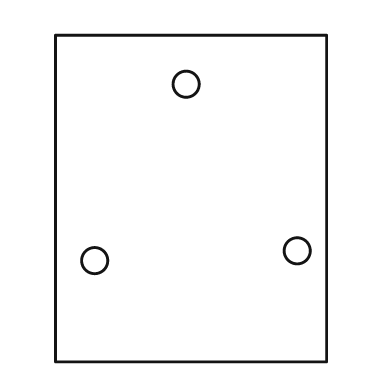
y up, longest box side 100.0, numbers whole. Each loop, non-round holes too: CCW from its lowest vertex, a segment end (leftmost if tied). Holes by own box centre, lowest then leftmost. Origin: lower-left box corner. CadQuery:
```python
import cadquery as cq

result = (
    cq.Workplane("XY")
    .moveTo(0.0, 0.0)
    .lineTo(83.0, 0.0)
    .lineTo(83.0, 100.0)
    .lineTo(0.0, 100.0)
    .close()
    .moveTo(12.0, 31.0)
    .circle(4.0)
    .moveTo(74.0, 34.0)
    .circle(4.0)
    .moveTo(40.0, 85.0)
    .circle(4.0)
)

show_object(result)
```